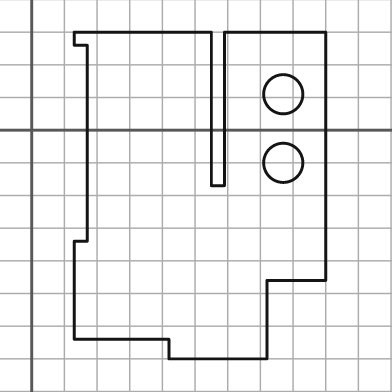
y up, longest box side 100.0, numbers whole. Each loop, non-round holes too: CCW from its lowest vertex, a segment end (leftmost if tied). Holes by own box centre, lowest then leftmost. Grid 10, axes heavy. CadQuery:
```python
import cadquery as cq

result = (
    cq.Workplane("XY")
    .moveTo(42.0, -70.0)
    .lineTo(72.0, -70.0)
    .lineTo(72.0, -46.0)
    .lineTo(90.0, -46.0)
    .lineTo(90.0, 30.0)
    .lineTo(59.0, 30.0)
    .lineTo(59.0, -17.0)
    .lineTo(55.0, -17.0)
    .lineTo(55.0, 30.0)
    .lineTo(13.0, 30.0)
    .lineTo(13.0, 26.0)
    .lineTo(17.0, 26.0)
    .lineTo(17.0, -34.0)
    .lineTo(13.0, -34.0)
    .lineTo(13.0, -64.0)
    .lineTo(42.0, -64.0)
    .close()
    .moveTo(77.0, -10.0)
    .circle(6.0)
    .moveTo(77.0, 11.0)
    .circle(6.0)
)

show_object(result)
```